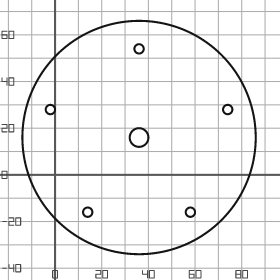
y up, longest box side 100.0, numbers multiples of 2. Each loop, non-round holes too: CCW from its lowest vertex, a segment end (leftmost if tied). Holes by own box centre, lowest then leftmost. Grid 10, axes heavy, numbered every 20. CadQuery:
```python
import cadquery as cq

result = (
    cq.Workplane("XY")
    .moveTo(36.0, 16.0)
    .circle(50.0)
    .moveTo(14.0, -16.0)
    .circle(2.0)
    .moveTo(58.0, -16.0)
    .circle(2.0)
    .moveTo(36.0, 16.0)
    .circle(4.0)
    .moveTo(-2.0, 28.0)
    .circle(2.0)
    .moveTo(74.0, 28.0)
    .circle(2.0)
    .moveTo(36.0, 54.0)
    .circle(2.0)
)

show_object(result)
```